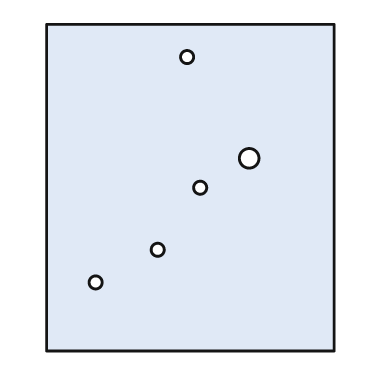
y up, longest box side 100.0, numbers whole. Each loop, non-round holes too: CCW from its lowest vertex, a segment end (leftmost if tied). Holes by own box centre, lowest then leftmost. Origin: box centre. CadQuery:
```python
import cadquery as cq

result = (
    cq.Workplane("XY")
    .moveTo(-44.0, -50.0)
    .lineTo(44.0, -50.0)
    .lineTo(44.0, 50.0)
    .lineTo(-44.0, 50.0)
    .close()
    .moveTo(-29.0, -29.0)
    .circle(2.0)
    .moveTo(-10.0, -19.0)
    .circle(2.0)
    .moveTo(3.0, 0.0)
    .circle(2.0)
    .moveTo(18.0, 9.0)
    .circle(3.0)
    .moveTo(-1.0, 40.0)
    .circle(2.0)
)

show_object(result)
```